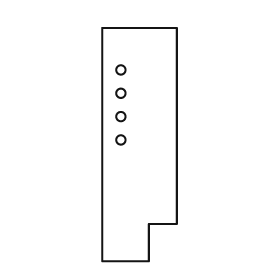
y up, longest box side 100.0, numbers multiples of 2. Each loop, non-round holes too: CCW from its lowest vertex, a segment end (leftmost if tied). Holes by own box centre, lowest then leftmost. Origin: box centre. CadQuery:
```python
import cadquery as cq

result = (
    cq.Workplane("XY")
    .moveTo(-16.0, -50.0)
    .lineTo(4.0, -50.0)
    .lineTo(4.0, -34.0)
    .lineTo(16.0, -34.0)
    .lineTo(16.0, 50.0)
    .lineTo(-16.0, 50.0)
    .close()
    .moveTo(-8.0, 2.0)
    .circle(2.0)
    .moveTo(-8.0, 12.0)
    .circle(2.0)
    .moveTo(-8.0, 22.0)
    .circle(2.0)
    .moveTo(-8.0, 32.0)
    .circle(2.0)
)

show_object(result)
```